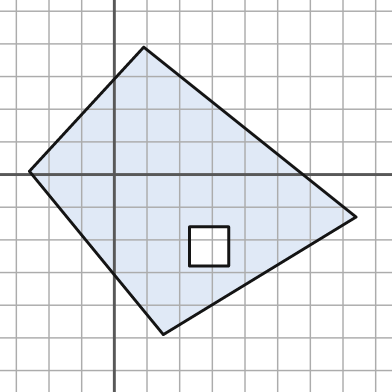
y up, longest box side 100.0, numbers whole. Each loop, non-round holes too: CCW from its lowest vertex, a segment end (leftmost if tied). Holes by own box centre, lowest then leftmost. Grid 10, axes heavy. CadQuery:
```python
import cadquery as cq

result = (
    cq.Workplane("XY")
    .moveTo(15.0, -49.0)
    .lineTo(74.0, -13.0)
    .lineTo(9.0, 39.0)
    .lineTo(-26.0, 1.0)
    .close()
    .moveTo(23.0, -28.0)
    .lineTo(35.0, -28.0)
    .lineTo(35.0, -16.0)
    .lineTo(23.0, -16.0)
    .close()
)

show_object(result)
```